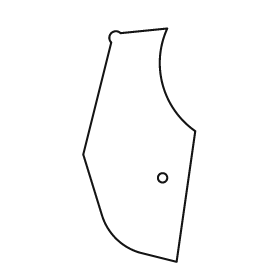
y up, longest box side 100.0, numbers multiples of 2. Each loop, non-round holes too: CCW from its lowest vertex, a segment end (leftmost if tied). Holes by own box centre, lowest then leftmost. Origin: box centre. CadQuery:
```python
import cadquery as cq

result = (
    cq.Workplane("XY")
    .moveTo(16.0, -50.0)
    .lineTo(24.0, 6.0)
    .threePointArc((10.0, 26.0), (12.0, 50.0))
    .lineTo(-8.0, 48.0)
    .threePointArc((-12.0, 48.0), (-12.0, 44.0))
    .lineTo(-24.0, -4.0)
    .lineTo(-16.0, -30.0)
    .threePointArc((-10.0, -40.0), (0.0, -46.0))
    .close()
    .moveTo(10.0, -14.0)
    .circle(2.0)
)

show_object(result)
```